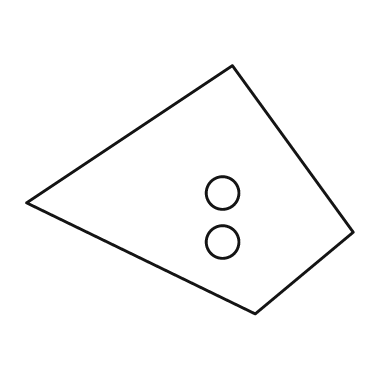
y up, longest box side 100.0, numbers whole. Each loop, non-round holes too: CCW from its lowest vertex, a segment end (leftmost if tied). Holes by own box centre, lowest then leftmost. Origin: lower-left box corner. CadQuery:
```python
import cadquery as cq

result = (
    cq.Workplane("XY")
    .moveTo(70.0, 0.0)
    .lineTo(100.0, 25.0)
    .lineTo(63.0, 76.0)
    .lineTo(0.0, 34.0)
    .close()
    .moveTo(60.0, 22.0)
    .circle(5.0)
    .moveTo(60.0, 37.0)
    .circle(5.0)
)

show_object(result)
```